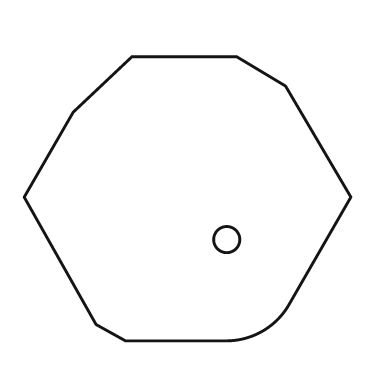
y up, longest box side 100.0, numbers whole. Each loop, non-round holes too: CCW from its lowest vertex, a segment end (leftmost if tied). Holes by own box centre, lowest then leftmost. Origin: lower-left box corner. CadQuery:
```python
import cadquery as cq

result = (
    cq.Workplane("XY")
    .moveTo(31.0, 0.0)
    .lineTo(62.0, 0.0)
    .threePointArc((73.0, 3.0), (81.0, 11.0))
    .lineTo(100.0, 44.0)
    .lineTo(80.0, 78.0)
    .lineTo(65.0, 87.0)
    .lineTo(33.0, 87.0)
    .lineTo(15.0, 70.0)
    .lineTo(0.0, 44.0)
    .lineTo(22.0, 5.0)
    .close()
    .moveTo(62.0, 31.0)
    .circle(4.0)
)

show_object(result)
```